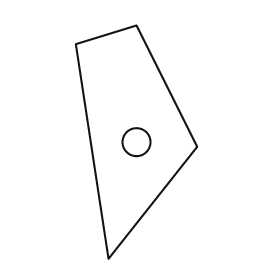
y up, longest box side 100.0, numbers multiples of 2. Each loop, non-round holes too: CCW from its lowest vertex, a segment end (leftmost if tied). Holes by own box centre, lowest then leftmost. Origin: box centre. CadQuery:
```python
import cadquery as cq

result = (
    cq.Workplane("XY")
    .moveTo(-12.0, -50.0)
    .lineTo(26.0, -2.0)
    .lineTo(0.0, 50.0)
    .lineTo(-26.0, 42.0)
    .close()
    .moveTo(0.0, 0.0)
    .circle(6.0)
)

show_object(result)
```